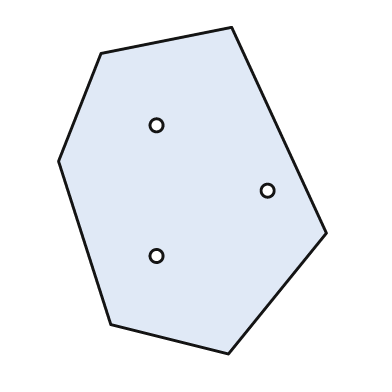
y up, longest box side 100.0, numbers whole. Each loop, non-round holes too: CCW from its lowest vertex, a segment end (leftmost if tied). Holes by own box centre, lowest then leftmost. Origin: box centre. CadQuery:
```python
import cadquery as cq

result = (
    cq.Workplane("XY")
    .moveTo(11.0, -50.0)
    .lineTo(41.0, -13.0)
    .lineTo(12.0, 50.0)
    .lineTo(-28.0, 42.0)
    .lineTo(-41.0, 9.0)
    .lineTo(-25.0, -41.0)
    .close()
    .moveTo(-11.0, -20.0)
    .circle(2.0)
    .moveTo(23.0, 0.0)
    .circle(2.0)
    .moveTo(-11.0, 20.0)
    .circle(2.0)
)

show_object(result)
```